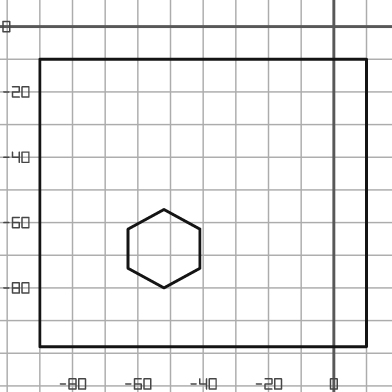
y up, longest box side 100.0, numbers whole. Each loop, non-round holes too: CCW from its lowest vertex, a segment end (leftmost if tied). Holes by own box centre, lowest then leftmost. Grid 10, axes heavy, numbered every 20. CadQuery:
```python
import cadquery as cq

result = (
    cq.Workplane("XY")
    .moveTo(-90.0, -98.0)
    .lineTo(10.0, -98.0)
    .lineTo(10.0, -10.0)
    .lineTo(-90.0, -10.0)
    .close()
    .moveTo(-52.0, -80.0)
    .lineTo(-41.0, -74.0)
    .lineTo(-41.0, -62.0)
    .lineTo(-52.0, -56.0)
    .lineTo(-63.0, -62.0)
    .lineTo(-63.0, -74.0)
    .close()
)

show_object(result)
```